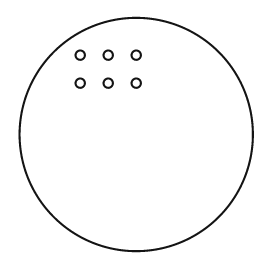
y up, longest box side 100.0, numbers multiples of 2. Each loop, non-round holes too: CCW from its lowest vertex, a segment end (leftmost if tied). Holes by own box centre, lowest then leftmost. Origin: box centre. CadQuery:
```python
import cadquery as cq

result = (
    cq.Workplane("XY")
    .moveTo(0.0, 0.0)
    .circle(50.0)
    .moveTo(-24.0, 22.0)
    .circle(2.0)
    .moveTo(-12.0, 22.0)
    .circle(2.0)
    .moveTo(0.0, 22.0)
    .circle(2.0)
    .moveTo(-24.0, 34.0)
    .circle(2.0)
    .moveTo(-12.0, 34.0)
    .circle(2.0)
    .moveTo(0.0, 34.0)
    .circle(2.0)
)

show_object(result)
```